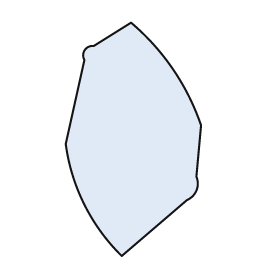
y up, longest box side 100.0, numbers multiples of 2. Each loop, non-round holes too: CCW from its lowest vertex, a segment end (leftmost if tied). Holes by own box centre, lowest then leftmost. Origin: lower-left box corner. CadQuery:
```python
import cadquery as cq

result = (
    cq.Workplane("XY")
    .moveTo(24.0, 0.0)
    .lineTo(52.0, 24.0)
    .threePointArc((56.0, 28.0), (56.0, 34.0))
    .lineTo(58.0, 56.0)
    .threePointArc((46.0, 80.0), (28.0, 100.0))
    .lineTo(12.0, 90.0)
    .threePointArc((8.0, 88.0), (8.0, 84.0))
    .lineTo(0.0, 48.0)
    .threePointArc((8.0, 22.0), (24.0, 0.0))
    .close()
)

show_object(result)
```